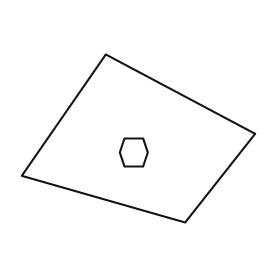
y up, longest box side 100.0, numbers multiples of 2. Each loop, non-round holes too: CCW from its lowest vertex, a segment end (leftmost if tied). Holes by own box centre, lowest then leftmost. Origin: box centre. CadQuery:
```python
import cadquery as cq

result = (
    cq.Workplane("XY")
    .moveTo(20.0, -36.0)
    .lineTo(50.0, 2.0)
    .lineTo(-14.0, 36.0)
    .lineTo(-50.0, -16.0)
    .close()
    .moveTo(-6.0, -12.0)
    .lineTo(2.0, -12.0)
    .lineTo(4.0, -6.0)
    .lineTo(2.0, 0.0)
    .lineTo(-6.0, 0.0)
    .lineTo(-8.0, -6.0)
    .close()
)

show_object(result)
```